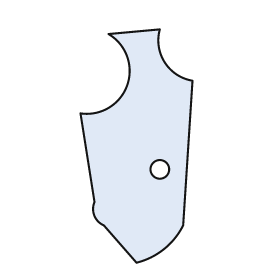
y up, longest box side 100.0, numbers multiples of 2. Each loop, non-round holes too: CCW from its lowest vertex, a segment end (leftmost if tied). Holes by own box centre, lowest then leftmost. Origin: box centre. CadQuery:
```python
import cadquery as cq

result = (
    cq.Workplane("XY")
    .moveTo(0.0, -50.0)
    .threePointArc((12.0, -44.0), (20.0, -34.0))
    .lineTo(24.0, 28.0)
    .threePointArc((12.0, 36.0), (10.0, 50.0))
    .lineTo(-12.0, 48.0)
    .threePointArc((-4.0, 26.0), (-24.0, 14.0))
    .lineTo(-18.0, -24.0)
    .threePointArc((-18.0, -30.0), (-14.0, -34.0))
    .close()
    .moveTo(10.0, -10.0)
    .circle(4.0)
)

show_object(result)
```